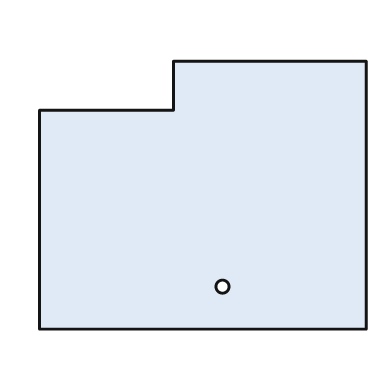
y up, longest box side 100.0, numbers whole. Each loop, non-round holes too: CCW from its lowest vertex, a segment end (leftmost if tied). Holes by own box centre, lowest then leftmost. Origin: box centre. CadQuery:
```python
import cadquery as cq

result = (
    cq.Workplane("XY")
    .moveTo(-50.0, -41.0)
    .lineTo(50.0, -41.0)
    .lineTo(50.0, 41.0)
    .lineTo(-9.0, 41.0)
    .lineTo(-9.0, 26.0)
    .lineTo(-50.0, 26.0)
    .close()
    .moveTo(6.0, -28.0)
    .circle(2.0)
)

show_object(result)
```